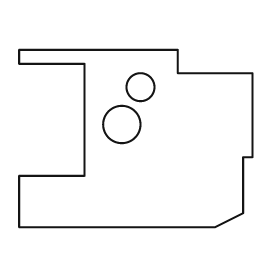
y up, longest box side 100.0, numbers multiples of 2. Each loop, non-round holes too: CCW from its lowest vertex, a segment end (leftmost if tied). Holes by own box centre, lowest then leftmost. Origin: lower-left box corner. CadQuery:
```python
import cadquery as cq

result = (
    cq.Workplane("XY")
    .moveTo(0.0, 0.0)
    .lineTo(84.0, 0.0)
    .lineTo(96.0, 6.0)
    .lineTo(96.0, 30.0)
    .lineTo(100.0, 30.0)
    .lineTo(100.0, 66.0)
    .lineTo(68.0, 66.0)
    .lineTo(68.0, 76.0)
    .lineTo(0.0, 76.0)
    .lineTo(0.0, 70.0)
    .lineTo(28.0, 70.0)
    .lineTo(28.0, 22.0)
    .lineTo(0.0, 22.0)
    .close()
    .moveTo(44.0, 44.0)
    .circle(8.0)
    .moveTo(52.0, 60.0)
    .circle(6.0)
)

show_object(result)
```